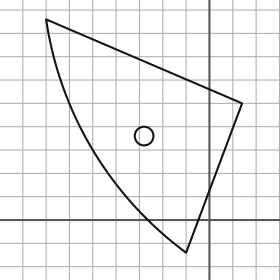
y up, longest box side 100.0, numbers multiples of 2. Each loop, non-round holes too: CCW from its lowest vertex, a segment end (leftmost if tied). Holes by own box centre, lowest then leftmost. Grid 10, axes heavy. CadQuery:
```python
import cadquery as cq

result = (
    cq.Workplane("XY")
    .moveTo(-10.0, -14.0)
    .lineTo(14.0, 50.0)
    .lineTo(-70.0, 86.0)
    .threePointArc((-50.0, 30.0), (-10.0, -14.0))
    .close()
    .moveTo(-28.0, 36.0)
    .circle(4.0)
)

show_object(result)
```